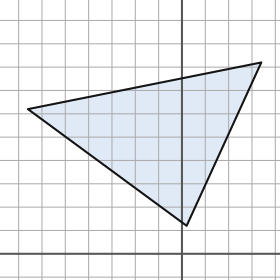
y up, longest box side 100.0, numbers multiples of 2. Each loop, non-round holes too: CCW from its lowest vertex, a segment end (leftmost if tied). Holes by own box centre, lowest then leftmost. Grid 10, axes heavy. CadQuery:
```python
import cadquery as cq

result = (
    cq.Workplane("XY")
    .moveTo(2.0, 12.0)
    .lineTo(34.0, 82.0)
    .lineTo(-66.0, 62.0)
    .close()
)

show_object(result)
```